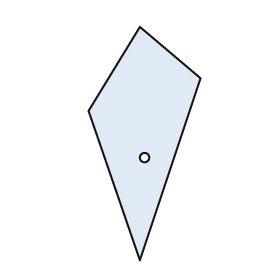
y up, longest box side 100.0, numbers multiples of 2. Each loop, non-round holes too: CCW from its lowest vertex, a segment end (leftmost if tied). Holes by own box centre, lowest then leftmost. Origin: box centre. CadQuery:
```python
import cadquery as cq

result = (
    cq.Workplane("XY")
    .moveTo(-2.0, -50.0)
    .lineTo(24.0, 28.0)
    .lineTo(-2.0, 50.0)
    .lineTo(-24.0, 14.0)
    .close()
    .moveTo(0.0, -6.0)
    .circle(2.0)
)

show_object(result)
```